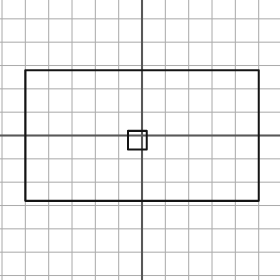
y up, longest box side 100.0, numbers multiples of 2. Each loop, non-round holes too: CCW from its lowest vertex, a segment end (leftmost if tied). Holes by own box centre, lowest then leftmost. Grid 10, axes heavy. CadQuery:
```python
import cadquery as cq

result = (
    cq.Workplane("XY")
    .moveTo(-50.0, -28.0)
    .lineTo(50.0, -28.0)
    .lineTo(50.0, 28.0)
    .lineTo(-50.0, 28.0)
    .close()
    .moveTo(-6.0, -6.0)
    .lineTo(2.0, -6.0)
    .lineTo(2.0, 2.0)
    .lineTo(-6.0, 2.0)
    .close()
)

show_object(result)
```